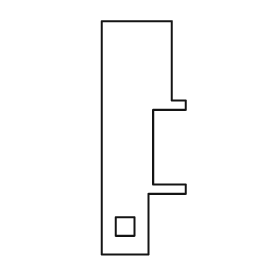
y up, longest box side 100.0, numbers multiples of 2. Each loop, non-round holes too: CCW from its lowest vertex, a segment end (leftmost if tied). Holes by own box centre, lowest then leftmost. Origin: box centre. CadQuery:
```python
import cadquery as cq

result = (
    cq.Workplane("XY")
    .moveTo(-18.0, -50.0)
    .lineTo(2.0, -50.0)
    .lineTo(2.0, -24.0)
    .lineTo(18.0, -24.0)
    .lineTo(18.0, -20.0)
    .lineTo(4.0, -20.0)
    .lineTo(4.0, 12.0)
    .lineTo(18.0, 12.0)
    .lineTo(18.0, 16.0)
    .lineTo(12.0, 16.0)
    .lineTo(12.0, 50.0)
    .lineTo(-18.0, 50.0)
    .close()
    .moveTo(-12.0, -42.0)
    .lineTo(-4.0, -42.0)
    .lineTo(-4.0, -34.0)
    .lineTo(-12.0, -34.0)
    .close()
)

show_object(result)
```